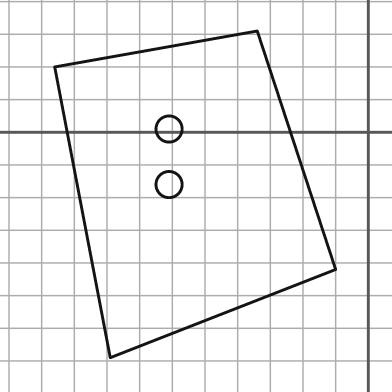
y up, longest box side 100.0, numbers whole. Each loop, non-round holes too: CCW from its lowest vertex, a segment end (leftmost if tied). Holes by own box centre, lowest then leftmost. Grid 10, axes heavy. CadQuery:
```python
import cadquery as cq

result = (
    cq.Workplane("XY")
    .moveTo(-79.0, -69.0)
    .lineTo(-10.0, -42.0)
    .lineTo(-34.0, 31.0)
    .lineTo(-96.0, 20.0)
    .close()
    .moveTo(-61.0, -16.0)
    .circle(4.0)
    .moveTo(-61.0, 1.0)
    .circle(4.0)
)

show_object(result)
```